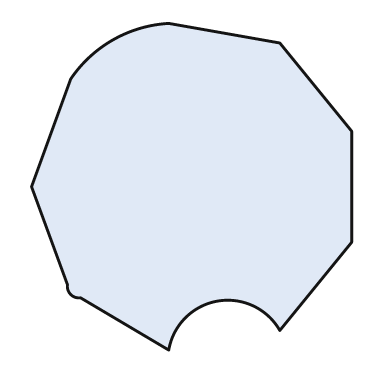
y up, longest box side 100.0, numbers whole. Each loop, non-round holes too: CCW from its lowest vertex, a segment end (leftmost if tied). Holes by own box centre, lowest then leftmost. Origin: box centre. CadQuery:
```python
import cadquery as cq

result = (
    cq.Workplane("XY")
    .moveTo(-7.0, -50.0)
    .threePointArc((8.0, -35.0), (27.0, -44.0))
    .lineTo(49.0, -17.0)
    .lineTo(49.0, 17.0)
    .lineTo(27.0, 44.0)
    .lineTo(-7.0, 50.0)
    .threePointArc((-24.0, 45.0), (-37.0, 33.0))
    .lineTo(-49.0, 0.0)
    .lineTo(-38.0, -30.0)
    .threePointArc((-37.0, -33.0), (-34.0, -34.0))
    .close()
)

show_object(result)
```